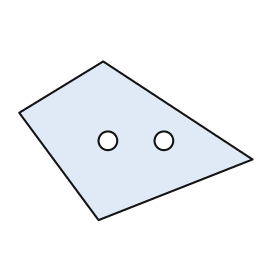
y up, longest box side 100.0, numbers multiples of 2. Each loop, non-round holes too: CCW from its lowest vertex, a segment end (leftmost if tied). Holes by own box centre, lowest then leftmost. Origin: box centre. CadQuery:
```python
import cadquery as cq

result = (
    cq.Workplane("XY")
    .moveTo(-16.0, -34.0)
    .lineTo(50.0, -8.0)
    .lineTo(-14.0, 34.0)
    .lineTo(-50.0, 12.0)
    .close()
    .moveTo(-12.0, 0.0)
    .circle(4.0)
    .moveTo(12.0, 0.0)
    .circle(4.0)
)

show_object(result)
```